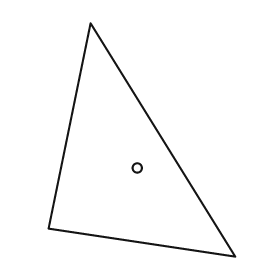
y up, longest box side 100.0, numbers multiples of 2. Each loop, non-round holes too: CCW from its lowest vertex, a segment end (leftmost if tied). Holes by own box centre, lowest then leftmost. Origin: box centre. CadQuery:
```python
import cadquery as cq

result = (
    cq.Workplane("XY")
    .moveTo(40.0, -50.0)
    .lineTo(-22.0, 50.0)
    .lineTo(-40.0, -38.0)
    .close()
    .moveTo(-2.0, -12.0)
    .circle(2.0)
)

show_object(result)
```